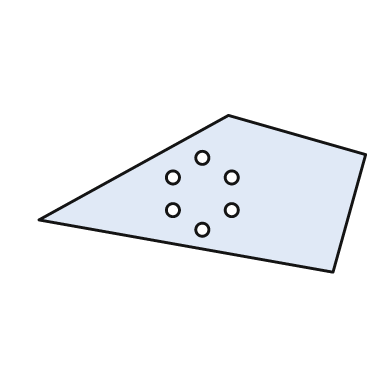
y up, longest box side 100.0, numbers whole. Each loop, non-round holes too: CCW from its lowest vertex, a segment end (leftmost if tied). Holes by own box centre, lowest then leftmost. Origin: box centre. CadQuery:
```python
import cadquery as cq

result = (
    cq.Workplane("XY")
    .moveTo(40.0, -24.0)
    .lineTo(50.0, 12.0)
    .lineTo(8.0, 24.0)
    .lineTo(-50.0, -8.0)
    .close()
    .moveTo(0.0, -11.0)
    .circle(2.0)
    .moveTo(-9.0, -5.0)
    .circle(2.0)
    .moveTo(9.0, -5.0)
    .circle(2.0)
    .moveTo(-9.0, 5.0)
    .circle(2.0)
    .moveTo(9.0, 5.0)
    .circle(2.0)
    .moveTo(0.0, 11.0)
    .circle(2.0)
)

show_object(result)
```